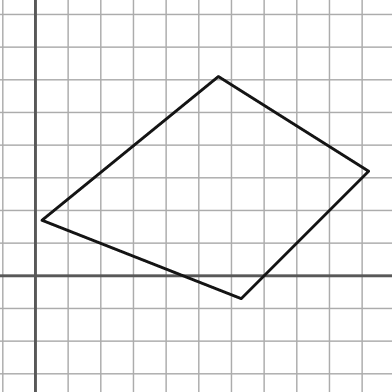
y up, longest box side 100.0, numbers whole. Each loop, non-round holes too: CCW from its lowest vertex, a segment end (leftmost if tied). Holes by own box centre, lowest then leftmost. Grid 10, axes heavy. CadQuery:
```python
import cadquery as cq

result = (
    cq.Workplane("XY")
    .moveTo(63.0, -7.0)
    .lineTo(102.0, 32.0)
    .lineTo(56.0, 61.0)
    .lineTo(2.0, 17.0)
    .close()
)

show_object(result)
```